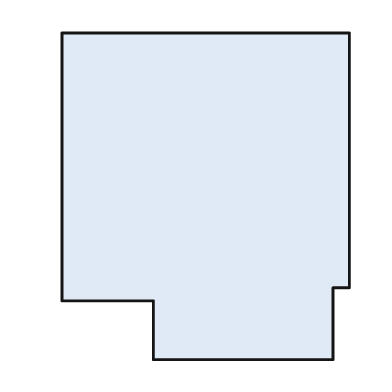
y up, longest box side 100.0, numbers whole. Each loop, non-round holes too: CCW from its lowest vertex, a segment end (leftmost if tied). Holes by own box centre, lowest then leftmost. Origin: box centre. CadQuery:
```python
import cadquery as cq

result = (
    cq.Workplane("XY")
    .moveTo(-16.0, -50.0)
    .lineTo(39.0, -50.0)
    .lineTo(39.0, -28.0)
    .lineTo(44.0, -28.0)
    .lineTo(44.0, 50.0)
    .lineTo(-44.0, 50.0)
    .lineTo(-44.0, -32.0)
    .lineTo(-16.0, -32.0)
    .close()
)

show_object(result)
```